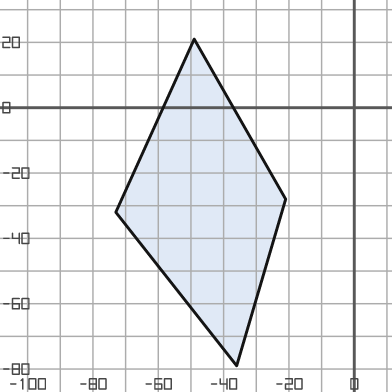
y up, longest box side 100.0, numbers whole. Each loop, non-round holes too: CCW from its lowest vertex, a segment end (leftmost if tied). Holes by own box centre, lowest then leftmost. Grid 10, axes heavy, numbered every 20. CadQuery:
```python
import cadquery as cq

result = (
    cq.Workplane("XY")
    .moveTo(-36.0, -79.0)
    .lineTo(-21.0, -28.0)
    .lineTo(-49.0, 21.0)
    .lineTo(-73.0, -32.0)
    .close()
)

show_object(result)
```